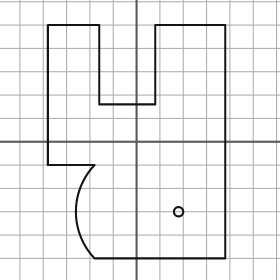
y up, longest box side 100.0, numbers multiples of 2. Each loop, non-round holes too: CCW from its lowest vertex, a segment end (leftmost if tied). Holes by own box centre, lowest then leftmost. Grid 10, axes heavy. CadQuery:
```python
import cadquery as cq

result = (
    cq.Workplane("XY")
    .moveTo(-18.0, -50.0)
    .lineTo(38.0, -50.0)
    .lineTo(38.0, 50.0)
    .lineTo(8.0, 50.0)
    .lineTo(8.0, 16.0)
    .lineTo(-16.0, 16.0)
    .lineTo(-16.0, 50.0)
    .lineTo(-38.0, 50.0)
    .lineTo(-38.0, -10.0)
    .lineTo(-18.0, -10.0)
    .threePointArc((-26.0, -30.0), (-18.0, -50.0))
    .close()
    .moveTo(18.0, -30.0)
    .circle(2.0)
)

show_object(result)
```